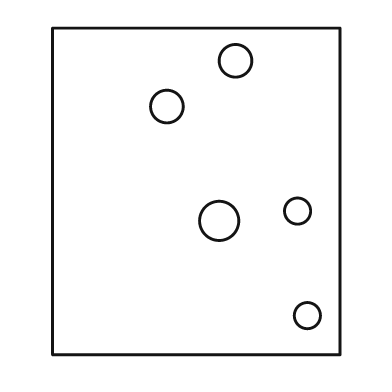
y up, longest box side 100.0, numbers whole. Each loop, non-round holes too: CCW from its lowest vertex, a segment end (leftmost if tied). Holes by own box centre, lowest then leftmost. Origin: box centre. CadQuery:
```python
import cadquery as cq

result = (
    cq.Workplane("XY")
    .moveTo(-44.0, -50.0)
    .lineTo(44.0, -50.0)
    .lineTo(44.0, 50.0)
    .lineTo(-44.0, 50.0)
    .close()
    .moveTo(34.0, -38.0)
    .circle(4.0)
    .moveTo(7.0, -9.0)
    .circle(6.0)
    .moveTo(31.0, -6.0)
    .circle(4.0)
    .moveTo(-9.0, 26.0)
    .circle(5.0)
    .moveTo(12.0, 40.0)
    .circle(5.0)
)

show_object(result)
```